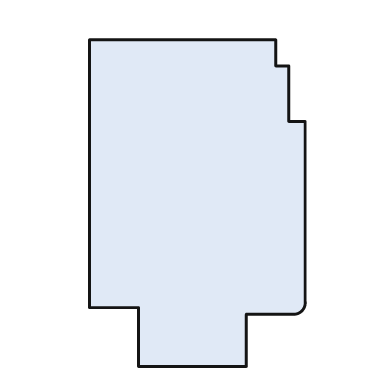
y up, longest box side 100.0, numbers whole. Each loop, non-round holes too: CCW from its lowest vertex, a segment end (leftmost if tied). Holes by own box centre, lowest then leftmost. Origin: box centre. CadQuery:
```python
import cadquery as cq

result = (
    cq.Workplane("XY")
    .moveTo(-18.0, -50.0)
    .lineTo(15.0, -50.0)
    .lineTo(15.0, -34.0)
    .lineTo(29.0, -34.0)
    .threePointArc((32.0, -33.0), (33.0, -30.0))
    .lineTo(33.0, 25.0)
    .lineTo(28.0, 25.0)
    .lineTo(28.0, 42.0)
    .lineTo(24.0, 42.0)
    .lineTo(24.0, 50.0)
    .lineTo(-33.0, 50.0)
    .lineTo(-33.0, -32.0)
    .lineTo(-18.0, -32.0)
    .close()
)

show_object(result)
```